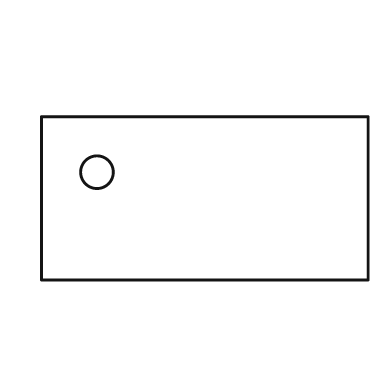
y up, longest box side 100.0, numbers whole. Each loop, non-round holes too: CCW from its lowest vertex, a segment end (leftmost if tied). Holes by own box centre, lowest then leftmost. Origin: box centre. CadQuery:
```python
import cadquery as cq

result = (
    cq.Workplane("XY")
    .moveTo(-50.0, -25.0)
    .lineTo(50.0, -25.0)
    .lineTo(50.0, 25.0)
    .lineTo(-50.0, 25.0)
    .close()
    .moveTo(-33.0, 8.0)
    .circle(5.0)
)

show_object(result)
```